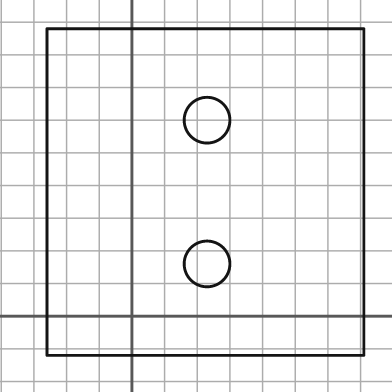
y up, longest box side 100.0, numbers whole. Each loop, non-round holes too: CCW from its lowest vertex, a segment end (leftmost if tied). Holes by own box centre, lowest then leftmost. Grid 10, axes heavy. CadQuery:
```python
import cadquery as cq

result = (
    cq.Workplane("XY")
    .moveTo(-26.0, -12.0)
    .lineTo(71.0, -12.0)
    .lineTo(71.0, 88.0)
    .lineTo(-26.0, 88.0)
    .close()
    .moveTo(23.0, 16.0)
    .circle(7.0)
    .moveTo(23.0, 60.0)
    .circle(7.0)
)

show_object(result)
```